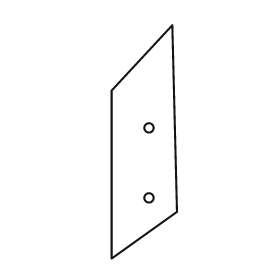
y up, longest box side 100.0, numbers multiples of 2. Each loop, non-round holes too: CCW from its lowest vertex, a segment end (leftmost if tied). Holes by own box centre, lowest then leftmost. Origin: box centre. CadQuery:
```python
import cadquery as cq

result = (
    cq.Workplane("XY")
    .moveTo(-14.0, -50.0)
    .lineTo(14.0, -30.0)
    .lineTo(12.0, 50.0)
    .lineTo(-14.0, 22.0)
    .close()
    .moveTo(2.0, -24.0)
    .circle(2.0)
    .moveTo(2.0, 6.0)
    .circle(2.0)
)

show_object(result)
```